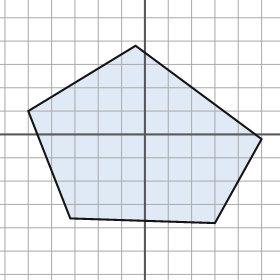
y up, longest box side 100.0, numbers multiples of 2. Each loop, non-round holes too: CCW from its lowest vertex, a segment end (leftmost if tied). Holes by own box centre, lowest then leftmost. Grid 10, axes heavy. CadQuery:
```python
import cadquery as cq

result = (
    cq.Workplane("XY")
    .moveTo(30.0, -38.0)
    .lineTo(50.0, -2.0)
    .lineTo(-4.0, 38.0)
    .lineTo(-50.0, 10.0)
    .lineTo(-32.0, -36.0)
    .close()
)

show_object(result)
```